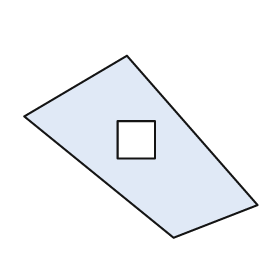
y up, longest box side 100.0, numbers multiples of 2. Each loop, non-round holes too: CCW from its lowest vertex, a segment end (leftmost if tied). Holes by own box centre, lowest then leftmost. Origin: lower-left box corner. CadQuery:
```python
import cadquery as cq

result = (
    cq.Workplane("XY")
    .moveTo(64.0, 0.0)
    .lineTo(100.0, 14.0)
    .lineTo(44.0, 78.0)
    .lineTo(0.0, 52.0)
    .close()
    .moveTo(40.0, 34.0)
    .lineTo(56.0, 34.0)
    .lineTo(56.0, 50.0)
    .lineTo(40.0, 50.0)
    .close()
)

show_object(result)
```